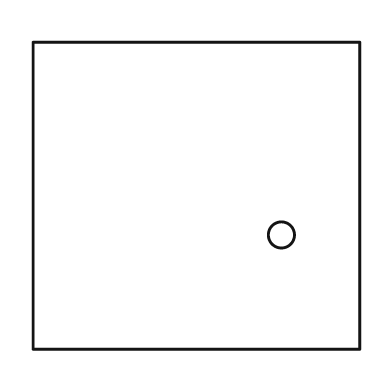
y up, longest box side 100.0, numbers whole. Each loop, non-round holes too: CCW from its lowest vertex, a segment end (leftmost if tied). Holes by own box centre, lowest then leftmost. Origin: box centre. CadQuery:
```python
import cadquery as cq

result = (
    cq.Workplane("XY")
    .moveTo(-50.0, -47.0)
    .lineTo(50.0, -47.0)
    .lineTo(50.0, 47.0)
    .lineTo(-50.0, 47.0)
    .close()
    .moveTo(26.0, -12.0)
    .circle(4.0)
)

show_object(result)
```